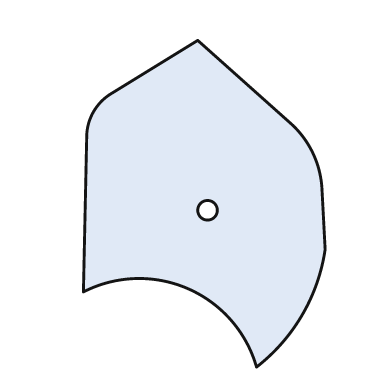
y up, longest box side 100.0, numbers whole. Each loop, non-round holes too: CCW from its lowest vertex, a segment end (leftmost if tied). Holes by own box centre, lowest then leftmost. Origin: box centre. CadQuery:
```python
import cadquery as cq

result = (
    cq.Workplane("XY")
    .moveTo(16.0, -50.0)
    .threePointArc((30.0, -34.0), (37.0, -14.0))
    .lineTo(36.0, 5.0)
    .threePointArc((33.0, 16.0), (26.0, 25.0))
    .lineTo(-2.0, 50.0)
    .lineTo(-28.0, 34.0)
    .threePointArc((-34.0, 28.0), (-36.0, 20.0))
    .lineTo(-37.0, -27.0)
    .threePointArc((-5.0, -26.0), (16.0, -50.0))
    .close()
    .moveTo(1.0, -2.0)
    .circle(3.0)
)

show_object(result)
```